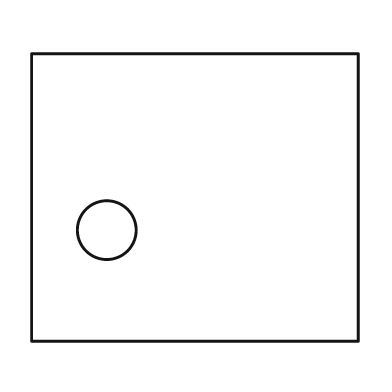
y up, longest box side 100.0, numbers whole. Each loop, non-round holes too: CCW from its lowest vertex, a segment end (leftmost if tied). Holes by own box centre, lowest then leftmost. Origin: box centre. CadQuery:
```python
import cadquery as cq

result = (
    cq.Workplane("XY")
    .moveTo(-50.0, -44.0)
    .lineTo(50.0, -44.0)
    .lineTo(50.0, 44.0)
    .lineTo(-50.0, 44.0)
    .close()
    .moveTo(-27.0, -10.0)
    .circle(9.0)
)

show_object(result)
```